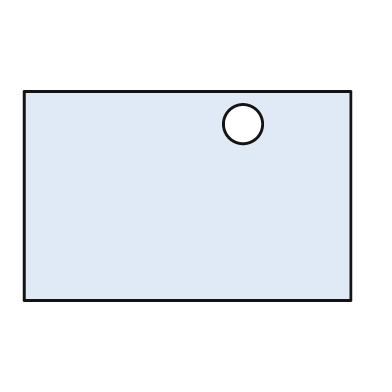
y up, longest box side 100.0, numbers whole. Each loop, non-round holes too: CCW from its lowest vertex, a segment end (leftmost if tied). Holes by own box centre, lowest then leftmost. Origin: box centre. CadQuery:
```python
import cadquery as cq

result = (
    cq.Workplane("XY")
    .moveTo(-50.0, -32.0)
    .lineTo(50.0, -32.0)
    .lineTo(50.0, 32.0)
    .lineTo(-50.0, 32.0)
    .close()
    .moveTo(17.0, 22.0)
    .circle(6.0)
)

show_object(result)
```